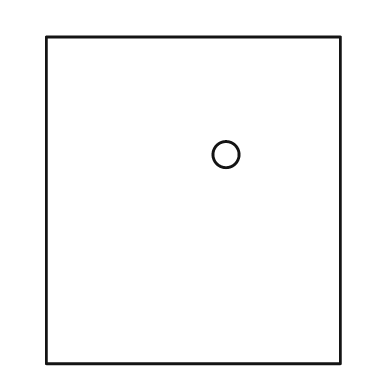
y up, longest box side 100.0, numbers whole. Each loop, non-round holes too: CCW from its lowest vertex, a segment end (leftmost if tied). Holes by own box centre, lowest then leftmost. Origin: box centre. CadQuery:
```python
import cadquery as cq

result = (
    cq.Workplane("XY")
    .moveTo(-45.0, -50.0)
    .lineTo(45.0, -50.0)
    .lineTo(45.0, 50.0)
    .lineTo(-45.0, 50.0)
    .close()
    .moveTo(10.0, 14.0)
    .circle(4.0)
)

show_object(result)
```